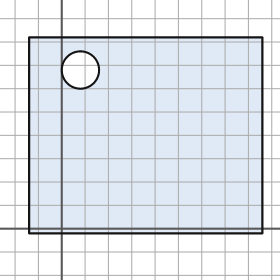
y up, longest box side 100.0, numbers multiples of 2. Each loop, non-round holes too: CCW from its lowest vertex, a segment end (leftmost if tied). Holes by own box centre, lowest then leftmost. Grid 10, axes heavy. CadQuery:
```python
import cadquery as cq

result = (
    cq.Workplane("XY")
    .moveTo(-14.0, -2.0)
    .lineTo(86.0, -2.0)
    .lineTo(86.0, 82.0)
    .lineTo(-14.0, 82.0)
    .close()
    .moveTo(8.0, 68.0)
    .circle(8.0)
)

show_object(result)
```